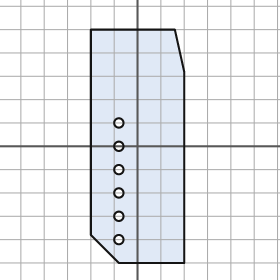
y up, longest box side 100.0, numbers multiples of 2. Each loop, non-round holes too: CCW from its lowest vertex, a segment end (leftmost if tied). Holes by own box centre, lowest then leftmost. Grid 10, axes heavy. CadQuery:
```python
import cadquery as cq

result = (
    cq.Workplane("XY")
    .moveTo(-8.0, -50.0)
    .lineTo(20.0, -50.0)
    .lineTo(20.0, 32.0)
    .lineTo(16.0, 50.0)
    .lineTo(-20.0, 50.0)
    .lineTo(-20.0, -38.0)
    .close()
    .moveTo(-8.0, -40.0)
    .circle(2.0)
    .moveTo(-8.0, -30.0)
    .circle(2.0)
    .moveTo(-8.0, -20.0)
    .circle(2.0)
    .moveTo(-8.0, -10.0)
    .circle(2.0)
    .moveTo(-8.0, 0.0)
    .circle(2.0)
    .moveTo(-8.0, 10.0)
    .circle(2.0)
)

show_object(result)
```